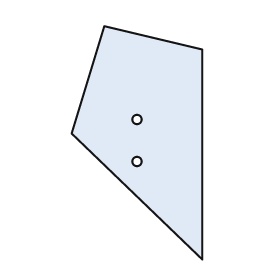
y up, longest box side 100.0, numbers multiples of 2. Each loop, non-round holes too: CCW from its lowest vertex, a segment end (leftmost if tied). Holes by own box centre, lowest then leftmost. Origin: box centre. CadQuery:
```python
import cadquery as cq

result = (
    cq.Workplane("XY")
    .moveTo(28.0, -50.0)
    .lineTo(28.0, 40.0)
    .lineTo(-14.0, 50.0)
    .lineTo(-28.0, 4.0)
    .close()
    .moveTo(0.0, -8.0)
    .circle(2.0)
    .moveTo(0.0, 10.0)
    .circle(2.0)
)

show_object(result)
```